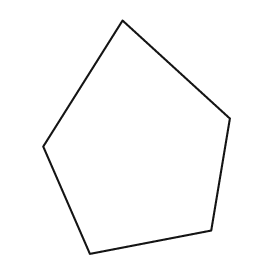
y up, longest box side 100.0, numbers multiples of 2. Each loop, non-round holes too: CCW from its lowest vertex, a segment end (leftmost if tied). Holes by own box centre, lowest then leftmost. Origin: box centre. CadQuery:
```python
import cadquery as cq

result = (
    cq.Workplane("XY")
    .moveTo(-20.0, -50.0)
    .lineTo(32.0, -40.0)
    .lineTo(40.0, 8.0)
    .lineTo(-6.0, 50.0)
    .lineTo(-40.0, -4.0)
    .close()
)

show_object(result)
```